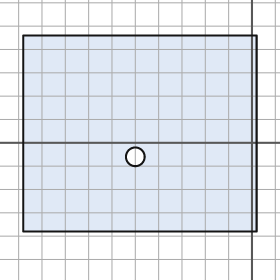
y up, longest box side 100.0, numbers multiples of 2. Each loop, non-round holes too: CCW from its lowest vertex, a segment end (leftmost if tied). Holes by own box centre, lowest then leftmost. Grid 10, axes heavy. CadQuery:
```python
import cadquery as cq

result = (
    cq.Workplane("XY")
    .moveTo(-98.0, -38.0)
    .lineTo(2.0, -38.0)
    .lineTo(2.0, 46.0)
    .lineTo(-98.0, 46.0)
    .close()
    .moveTo(-50.0, -6.0)
    .circle(4.0)
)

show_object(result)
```